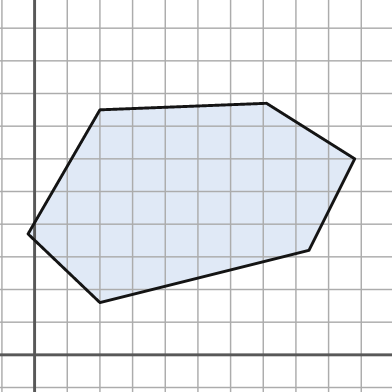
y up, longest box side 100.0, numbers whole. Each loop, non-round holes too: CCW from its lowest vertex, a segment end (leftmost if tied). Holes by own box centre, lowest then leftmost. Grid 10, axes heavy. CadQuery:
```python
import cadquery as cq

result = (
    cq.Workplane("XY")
    .moveTo(20.0, 16.0)
    .lineTo(84.0, 32.0)
    .lineTo(98.0, 60.0)
    .lineTo(71.0, 77.0)
    .lineTo(20.0, 75.0)
    .lineTo(-2.0, 37.0)
    .close()
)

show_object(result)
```